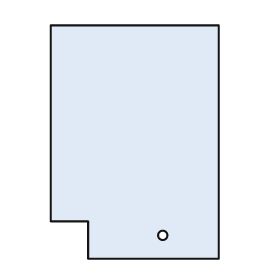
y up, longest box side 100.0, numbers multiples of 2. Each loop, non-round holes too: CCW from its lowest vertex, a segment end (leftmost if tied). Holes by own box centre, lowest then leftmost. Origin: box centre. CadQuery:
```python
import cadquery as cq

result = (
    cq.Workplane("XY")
    .moveTo(-20.0, -50.0)
    .lineTo(36.0, -50.0)
    .lineTo(36.0, 50.0)
    .lineTo(-36.0, 50.0)
    .lineTo(-36.0, -34.0)
    .lineTo(-20.0, -34.0)
    .close()
    .moveTo(12.0, -40.0)
    .circle(2.0)
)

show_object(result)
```